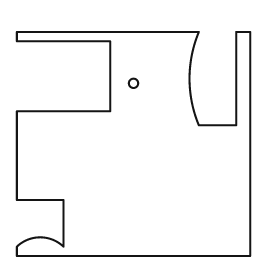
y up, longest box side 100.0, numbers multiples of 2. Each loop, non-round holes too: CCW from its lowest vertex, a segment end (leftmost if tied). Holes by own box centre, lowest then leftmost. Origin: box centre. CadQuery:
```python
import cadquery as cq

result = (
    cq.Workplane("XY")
    .moveTo(-50.0, -48.0)
    .lineTo(50.0, -48.0)
    .lineTo(50.0, 48.0)
    .lineTo(44.0, 48.0)
    .lineTo(44.0, 8.0)
    .lineTo(28.0, 8.0)
    .threePointArc((24.0, 28.0), (28.0, 48.0))
    .lineTo(-50.0, 48.0)
    .lineTo(-50.0, 44.0)
    .lineTo(-10.0, 44.0)
    .lineTo(-10.0, 14.0)
    .lineTo(-50.0, 14.0)
    .lineTo(-50.0, -24.0)
    .lineTo(-30.0, -24.0)
    .lineTo(-30.0, -44.0)
    .threePointArc((-40.0, -40.0), (-50.0, -44.0))
    .close()
    .moveTo(0.0, 26.0)
    .circle(2.0)
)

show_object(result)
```